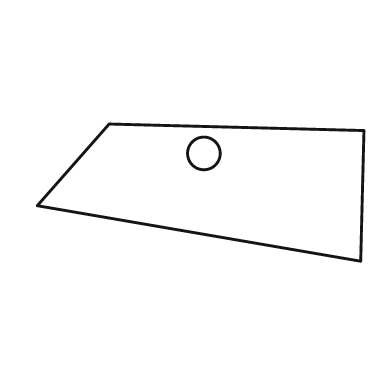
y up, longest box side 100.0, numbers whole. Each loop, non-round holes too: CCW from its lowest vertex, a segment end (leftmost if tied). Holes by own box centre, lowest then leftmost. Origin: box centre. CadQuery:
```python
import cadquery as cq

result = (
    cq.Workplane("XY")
    .moveTo(49.0, -21.0)
    .lineTo(50.0, 19.0)
    .lineTo(-28.0, 21.0)
    .lineTo(-50.0, -4.0)
    .close()
    .moveTo(1.0, 12.0)
    .circle(5.0)
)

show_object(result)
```